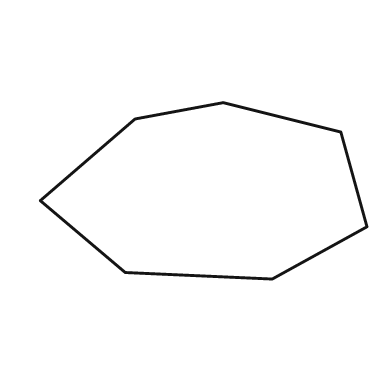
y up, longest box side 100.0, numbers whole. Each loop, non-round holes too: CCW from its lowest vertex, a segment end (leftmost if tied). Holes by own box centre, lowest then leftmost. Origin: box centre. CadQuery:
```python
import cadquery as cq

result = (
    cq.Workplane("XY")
    .moveTo(21.0, -27.0)
    .lineTo(50.0, -11.0)
    .lineTo(42.0, 18.0)
    .lineTo(6.0, 27.0)
    .lineTo(-21.0, 22.0)
    .lineTo(-50.0, -3.0)
    .lineTo(-24.0, -25.0)
    .close()
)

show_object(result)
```